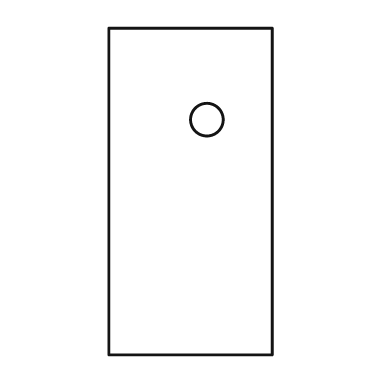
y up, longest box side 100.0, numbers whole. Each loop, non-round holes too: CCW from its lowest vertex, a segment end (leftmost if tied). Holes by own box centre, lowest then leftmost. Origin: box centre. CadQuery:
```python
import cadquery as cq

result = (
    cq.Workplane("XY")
    .moveTo(-25.0, -50.0)
    .lineTo(25.0, -50.0)
    .lineTo(25.0, 50.0)
    .lineTo(-25.0, 50.0)
    .close()
    .moveTo(5.0, 22.0)
    .circle(5.0)
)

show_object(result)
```